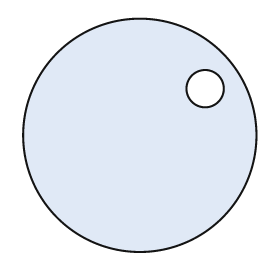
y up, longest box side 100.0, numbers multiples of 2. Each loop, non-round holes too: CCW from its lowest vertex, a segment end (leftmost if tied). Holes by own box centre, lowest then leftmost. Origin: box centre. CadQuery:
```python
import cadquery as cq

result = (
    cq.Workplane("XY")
    .moveTo(0.0, 0.0)
    .circle(50.0)
    .moveTo(28.0, 20.0)
    .circle(8.0)
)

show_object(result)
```